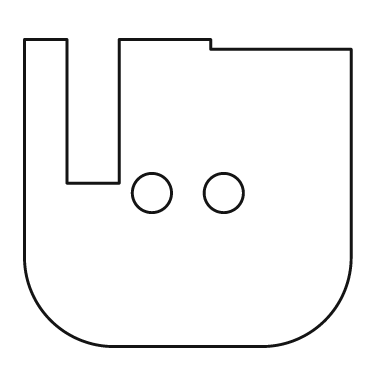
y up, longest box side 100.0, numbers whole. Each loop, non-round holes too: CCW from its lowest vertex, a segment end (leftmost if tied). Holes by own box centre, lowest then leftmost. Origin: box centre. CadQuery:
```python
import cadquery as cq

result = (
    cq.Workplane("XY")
    .moveTo(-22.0, -47.0)
    .lineTo(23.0, -47.0)
    .threePointArc((42.0, -39.0), (50.0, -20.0))
    .lineTo(50.0, 44.0)
    .lineTo(7.0, 44.0)
    .lineTo(7.0, 47.0)
    .lineTo(-21.0, 47.0)
    .lineTo(-21.0, 3.0)
    .lineTo(-37.0, 3.0)
    .lineTo(-37.0, 47.0)
    .lineTo(-50.0, 47.0)
    .lineTo(-50.0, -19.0)
    .threePointArc((-42.0, -39.0), (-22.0, -47.0))
    .close()
    .moveTo(-11.0, 0.0)
    .circle(6.0)
    .moveTo(11.0, 0.0)
    .circle(6.0)
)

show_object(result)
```